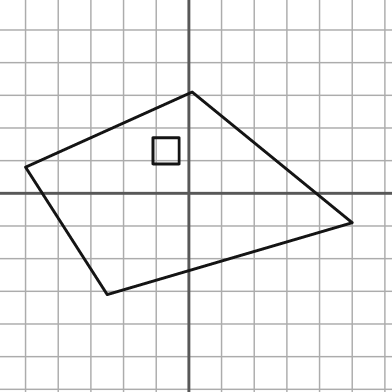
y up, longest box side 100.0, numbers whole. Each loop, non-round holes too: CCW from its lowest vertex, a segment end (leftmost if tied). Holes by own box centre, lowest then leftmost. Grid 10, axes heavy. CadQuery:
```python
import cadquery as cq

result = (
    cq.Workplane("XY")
    .moveTo(-25.0, -31.0)
    .lineTo(50.0, -9.0)
    .lineTo(1.0, 31.0)
    .lineTo(-50.0, 8.0)
    .close()
    .moveTo(-11.0, 9.0)
    .lineTo(-3.0, 9.0)
    .lineTo(-3.0, 17.0)
    .lineTo(-11.0, 17.0)
    .close()
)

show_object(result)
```